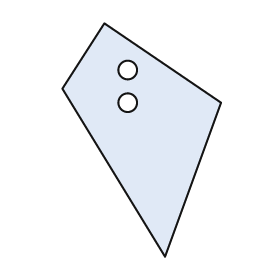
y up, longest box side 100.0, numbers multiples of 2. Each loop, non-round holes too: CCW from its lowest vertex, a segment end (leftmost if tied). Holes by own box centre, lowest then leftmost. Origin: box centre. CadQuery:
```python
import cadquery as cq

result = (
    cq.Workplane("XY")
    .moveTo(10.0, -50.0)
    .lineTo(34.0, 16.0)
    .lineTo(-16.0, 50.0)
    .lineTo(-34.0, 22.0)
    .close()
    .moveTo(-6.0, 16.0)
    .circle(4.0)
    .moveTo(-6.0, 30.0)
    .circle(4.0)
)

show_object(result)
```